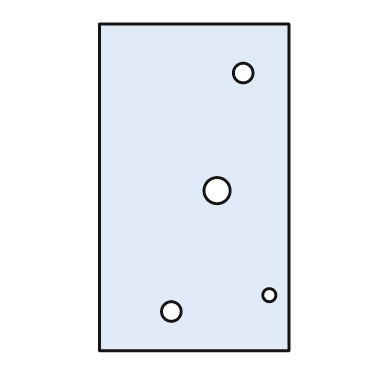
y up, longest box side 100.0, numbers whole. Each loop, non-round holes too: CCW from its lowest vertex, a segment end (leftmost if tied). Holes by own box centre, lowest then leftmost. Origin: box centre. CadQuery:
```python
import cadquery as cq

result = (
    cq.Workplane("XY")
    .moveTo(-29.0, -50.0)
    .lineTo(29.0, -50.0)
    .lineTo(29.0, 50.0)
    .lineTo(-29.0, 50.0)
    .close()
    .moveTo(-7.0, -38.0)
    .circle(3.0)
    .moveTo(23.0, -33.0)
    .circle(2.0)
    .moveTo(7.0, -1.0)
    .circle(4.0)
    .moveTo(15.0, 35.0)
    .circle(3.0)
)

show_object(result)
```